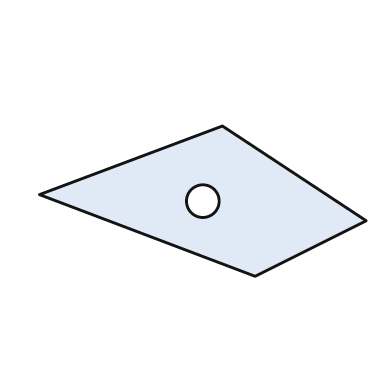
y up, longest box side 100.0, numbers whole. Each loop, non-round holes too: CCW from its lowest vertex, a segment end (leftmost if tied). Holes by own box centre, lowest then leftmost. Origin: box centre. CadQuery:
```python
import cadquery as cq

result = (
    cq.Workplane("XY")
    .moveTo(16.0, -23.0)
    .lineTo(50.0, -6.0)
    .lineTo(6.0, 23.0)
    .lineTo(-50.0, 2.0)
    .close()
    .moveTo(0.0, 0.0)
    .circle(5.0)
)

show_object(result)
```